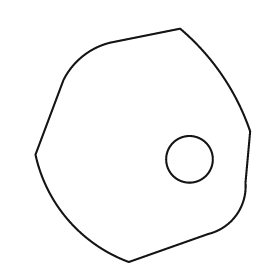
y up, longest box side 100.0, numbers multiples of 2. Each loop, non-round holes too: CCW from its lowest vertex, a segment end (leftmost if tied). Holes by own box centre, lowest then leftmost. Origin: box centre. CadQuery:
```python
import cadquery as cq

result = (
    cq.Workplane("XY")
    .moveTo(-6.0, -50.0)
    .lineTo(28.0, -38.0)
    .threePointArc((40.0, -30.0), (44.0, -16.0))
    .lineTo(46.0, 6.0)
    .threePointArc((34.0, 30.0), (16.0, 50.0))
    .lineTo(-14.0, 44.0)
    .threePointArc((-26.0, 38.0), (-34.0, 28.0))
    .lineTo(-46.0, -4.0)
    .threePointArc((-32.0, -32.0), (-6.0, -50.0))
    .close()
    .moveTo(20.0, -6.0)
    .circle(10.0)
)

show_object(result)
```